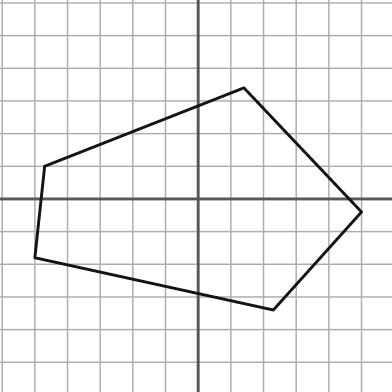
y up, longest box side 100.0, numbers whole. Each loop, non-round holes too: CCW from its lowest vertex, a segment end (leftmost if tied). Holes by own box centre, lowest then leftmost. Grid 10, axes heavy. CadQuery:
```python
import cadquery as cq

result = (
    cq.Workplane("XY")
    .moveTo(23.0, -34.0)
    .lineTo(50.0, -4.0)
    .lineTo(14.0, 34.0)
    .lineTo(-47.0, 10.0)
    .lineTo(-50.0, -18.0)
    .close()
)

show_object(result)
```